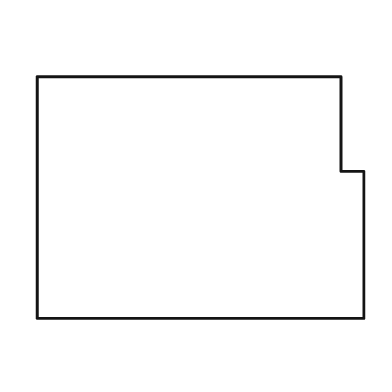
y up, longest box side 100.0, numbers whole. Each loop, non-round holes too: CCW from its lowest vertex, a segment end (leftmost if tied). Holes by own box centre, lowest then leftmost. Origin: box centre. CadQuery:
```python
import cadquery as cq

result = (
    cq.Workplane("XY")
    .moveTo(-50.0, -37.0)
    .lineTo(50.0, -37.0)
    .lineTo(50.0, 8.0)
    .lineTo(43.0, 8.0)
    .lineTo(43.0, 37.0)
    .lineTo(-50.0, 37.0)
    .close()
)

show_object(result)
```